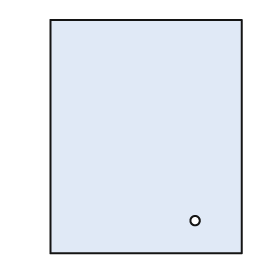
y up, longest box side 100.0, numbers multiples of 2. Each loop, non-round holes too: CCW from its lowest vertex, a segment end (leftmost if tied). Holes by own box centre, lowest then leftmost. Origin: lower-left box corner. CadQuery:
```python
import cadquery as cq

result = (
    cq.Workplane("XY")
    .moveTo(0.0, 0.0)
    .lineTo(82.0, 0.0)
    .lineTo(82.0, 100.0)
    .lineTo(0.0, 100.0)
    .close()
    .moveTo(62.0, 14.0)
    .circle(2.0)
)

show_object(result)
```